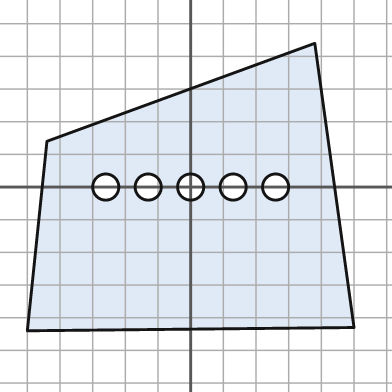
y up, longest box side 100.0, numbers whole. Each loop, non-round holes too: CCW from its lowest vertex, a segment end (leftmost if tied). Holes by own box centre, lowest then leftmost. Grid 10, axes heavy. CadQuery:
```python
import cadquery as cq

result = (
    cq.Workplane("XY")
    .moveTo(-50.0, -44.0)
    .lineTo(50.0, -43.0)
    .lineTo(38.0, 44.0)
    .lineTo(-44.0, 14.0)
    .close()
    .moveTo(-26.0, 0.0)
    .circle(4.0)
    .moveTo(-13.0, 0.0)
    .circle(4.0)
    .moveTo(0.0, 0.0)
    .circle(4.0)
    .moveTo(13.0, 0.0)
    .circle(4.0)
    .moveTo(26.0, 0.0)
    .circle(4.0)
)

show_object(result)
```